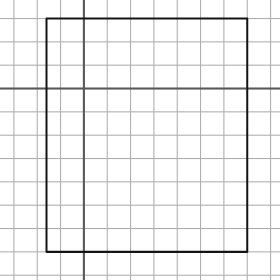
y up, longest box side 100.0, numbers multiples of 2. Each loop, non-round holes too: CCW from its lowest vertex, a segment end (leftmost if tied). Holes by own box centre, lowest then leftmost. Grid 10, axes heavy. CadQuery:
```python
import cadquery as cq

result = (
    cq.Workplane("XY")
    .moveTo(-16.0, -70.0)
    .lineTo(70.0, -70.0)
    .lineTo(70.0, 30.0)
    .lineTo(-16.0, 30.0)
    .close()
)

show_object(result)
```